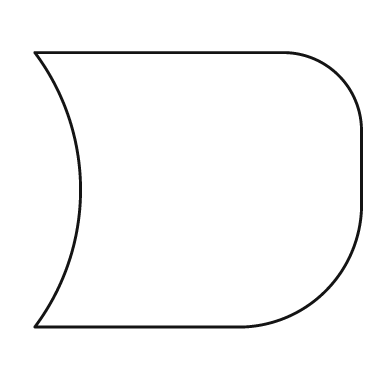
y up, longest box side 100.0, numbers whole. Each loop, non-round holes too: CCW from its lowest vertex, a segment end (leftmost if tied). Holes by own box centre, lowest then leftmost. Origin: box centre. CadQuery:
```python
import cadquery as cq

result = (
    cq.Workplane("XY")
    .moveTo(-50.0, -42.0)
    .lineTo(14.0, -42.0)
    .threePointArc((39.0, -31.0), (50.0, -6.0))
    .lineTo(50.0, 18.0)
    .threePointArc((43.0, 35.0), (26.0, 42.0))
    .lineTo(-50.0, 42.0)
    .threePointArc((-36.0, 0.0), (-50.0, -42.0))
    .close()
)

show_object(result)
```